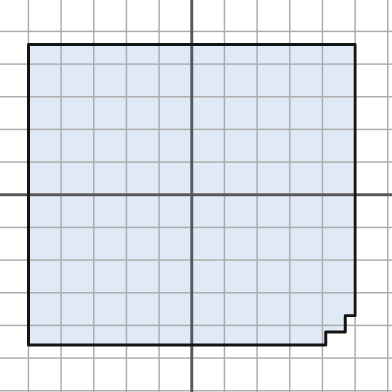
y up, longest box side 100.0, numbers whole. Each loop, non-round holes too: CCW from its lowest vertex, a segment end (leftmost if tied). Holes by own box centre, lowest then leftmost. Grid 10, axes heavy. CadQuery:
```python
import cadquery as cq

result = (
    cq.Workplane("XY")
    .moveTo(-50.0, -46.0)
    .lineTo(41.0, -46.0)
    .lineTo(41.0, -42.0)
    .lineTo(47.0, -42.0)
    .lineTo(47.0, -37.0)
    .lineTo(50.0, -37.0)
    .lineTo(50.0, 46.0)
    .lineTo(-50.0, 46.0)
    .close()
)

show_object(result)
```